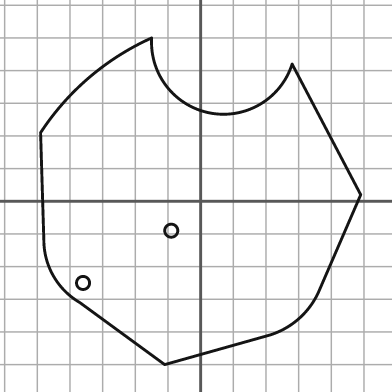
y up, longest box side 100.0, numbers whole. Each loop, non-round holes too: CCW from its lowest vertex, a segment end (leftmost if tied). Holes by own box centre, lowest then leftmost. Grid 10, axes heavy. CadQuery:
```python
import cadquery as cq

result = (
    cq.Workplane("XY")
    .moveTo(-11.0, -50.0)
    .lineTo(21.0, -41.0)
    .threePointArc((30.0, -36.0), (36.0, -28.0))
    .lineTo(49.0, 2.0)
    .lineTo(28.0, 42.0)
    .threePointArc((3.0, 27.0), (-15.0, 50.0))
    .threePointArc((-34.0, 38.0), (-49.0, 21.0))
    .lineTo(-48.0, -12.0)
    .threePointArc((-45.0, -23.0), (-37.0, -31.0))
    .close()
    .moveTo(-36.0, -25.0)
    .circle(2.0)
    .moveTo(-9.0, -9.0)
    .circle(2.0)
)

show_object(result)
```